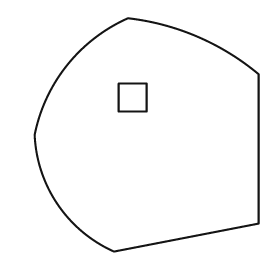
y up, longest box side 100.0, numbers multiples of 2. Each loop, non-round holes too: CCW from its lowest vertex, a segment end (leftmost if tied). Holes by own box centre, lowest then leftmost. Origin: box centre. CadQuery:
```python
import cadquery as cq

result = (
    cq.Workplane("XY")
    .moveTo(-14.0, -50.0)
    .lineTo(48.0, -38.0)
    .lineTo(48.0, 26.0)
    .threePointArc((22.0, 42.0), (-8.0, 50.0))
    .threePointArc((-34.0, 30.0), (-48.0, 0.0))
    .threePointArc((-38.0, -30.0), (-14.0, -50.0))
    .close()
    .moveTo(-12.0, 10.0)
    .lineTo(0.0, 10.0)
    .lineTo(0.0, 22.0)
    .lineTo(-12.0, 22.0)
    .close()
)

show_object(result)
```